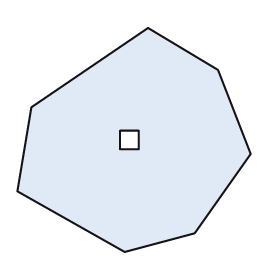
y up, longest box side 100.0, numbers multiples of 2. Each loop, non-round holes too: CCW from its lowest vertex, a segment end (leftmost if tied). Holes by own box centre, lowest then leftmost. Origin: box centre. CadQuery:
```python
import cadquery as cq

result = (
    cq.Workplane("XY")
    .moveTo(-4.0, -48.0)
    .lineTo(26.0, -40.0)
    .lineTo(50.0, -6.0)
    .lineTo(36.0, 30.0)
    .lineTo(6.0, 48.0)
    .lineTo(-44.0, 14.0)
    .lineTo(-50.0, -22.0)
    .close()
    .moveTo(-6.0, -4.0)
    .lineTo(2.0, -4.0)
    .lineTo(2.0, 4.0)
    .lineTo(-6.0, 4.0)
    .close()
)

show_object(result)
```